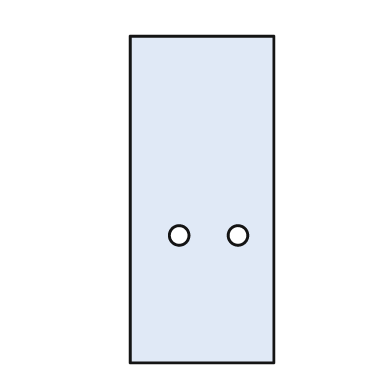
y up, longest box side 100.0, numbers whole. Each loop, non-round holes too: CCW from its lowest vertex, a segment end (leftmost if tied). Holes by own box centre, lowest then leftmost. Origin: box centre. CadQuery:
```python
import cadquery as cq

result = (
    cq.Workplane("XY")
    .moveTo(-22.0, -50.0)
    .lineTo(22.0, -50.0)
    .lineTo(22.0, 50.0)
    .lineTo(-22.0, 50.0)
    .close()
    .moveTo(-7.0, -11.0)
    .circle(3.0)
    .moveTo(11.0, -11.0)
    .circle(3.0)
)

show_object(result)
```